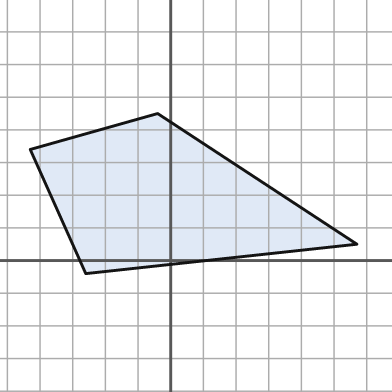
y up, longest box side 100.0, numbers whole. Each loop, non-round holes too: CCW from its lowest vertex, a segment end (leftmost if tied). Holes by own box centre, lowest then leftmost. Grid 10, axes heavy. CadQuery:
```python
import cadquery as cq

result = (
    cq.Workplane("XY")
    .moveTo(-26.0, -4.0)
    .lineTo(57.0, 5.0)
    .lineTo(-4.0, 45.0)
    .lineTo(-43.0, 34.0)
    .close()
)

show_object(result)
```